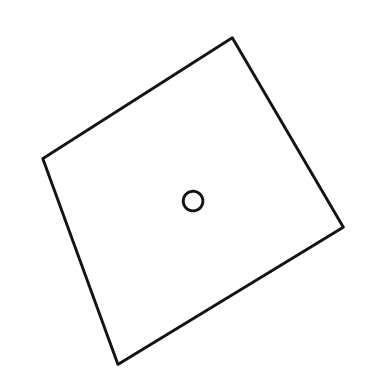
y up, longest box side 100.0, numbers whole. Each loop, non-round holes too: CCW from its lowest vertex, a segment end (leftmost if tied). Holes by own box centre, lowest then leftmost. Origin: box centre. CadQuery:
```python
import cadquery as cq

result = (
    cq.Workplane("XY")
    .moveTo(-23.0, -50.0)
    .lineTo(46.0, -8.0)
    .lineTo(12.0, 50.0)
    .lineTo(-46.0, 13.0)
    .close()
    .moveTo(0.0, 0.0)
    .circle(3.0)
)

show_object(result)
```